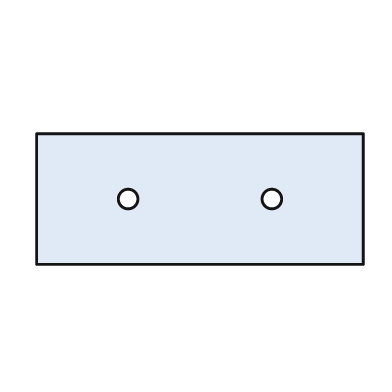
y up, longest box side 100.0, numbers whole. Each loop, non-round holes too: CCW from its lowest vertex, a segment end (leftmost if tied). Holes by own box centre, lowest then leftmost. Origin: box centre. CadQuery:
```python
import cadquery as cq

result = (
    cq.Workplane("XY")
    .moveTo(-50.0, -20.0)
    .lineTo(50.0, -20.0)
    .lineTo(50.0, 20.0)
    .lineTo(-50.0, 20.0)
    .close()
    .moveTo(-22.0, 0.0)
    .circle(3.0)
    .moveTo(22.0, 0.0)
    .circle(3.0)
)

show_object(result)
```